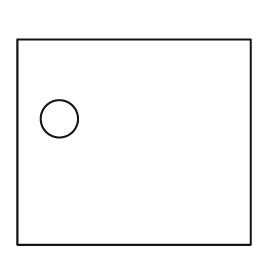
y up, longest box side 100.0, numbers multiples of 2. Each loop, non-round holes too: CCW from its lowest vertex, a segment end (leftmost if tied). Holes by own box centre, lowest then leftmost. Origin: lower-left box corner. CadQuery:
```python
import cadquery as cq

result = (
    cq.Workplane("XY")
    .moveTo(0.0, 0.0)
    .lineTo(100.0, 0.0)
    .lineTo(100.0, 88.0)
    .lineTo(0.0, 88.0)
    .close()
    .moveTo(18.0, 54.0)
    .circle(8.0)
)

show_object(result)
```